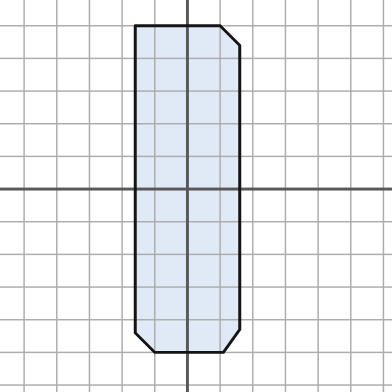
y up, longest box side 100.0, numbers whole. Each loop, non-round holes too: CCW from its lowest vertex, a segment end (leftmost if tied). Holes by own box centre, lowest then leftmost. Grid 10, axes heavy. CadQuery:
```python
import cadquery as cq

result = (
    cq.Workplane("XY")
    .moveTo(-10.0, -50.0)
    .lineTo(11.0, -50.0)
    .lineTo(16.0, -43.0)
    .lineTo(16.0, 44.0)
    .lineTo(10.0, 50.0)
    .lineTo(-16.0, 50.0)
    .lineTo(-16.0, -44.0)
    .close()
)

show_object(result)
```